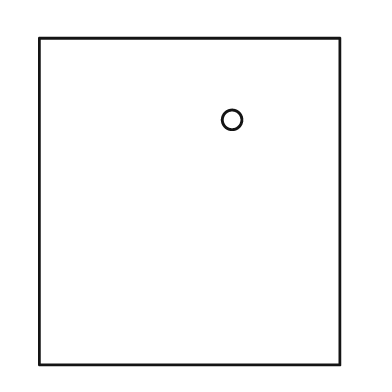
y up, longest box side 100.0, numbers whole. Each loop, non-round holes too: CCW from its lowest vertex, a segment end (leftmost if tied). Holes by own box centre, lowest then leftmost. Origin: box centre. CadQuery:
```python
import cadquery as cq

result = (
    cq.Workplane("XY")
    .moveTo(-46.0, -50.0)
    .lineTo(46.0, -50.0)
    .lineTo(46.0, 50.0)
    .lineTo(-46.0, 50.0)
    .close()
    .moveTo(13.0, 25.0)
    .circle(3.0)
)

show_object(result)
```